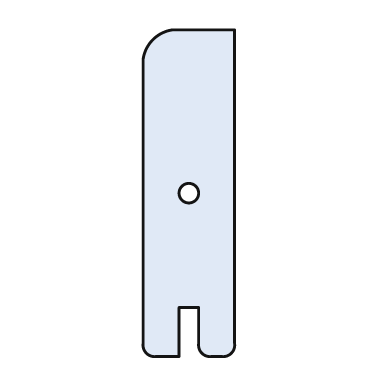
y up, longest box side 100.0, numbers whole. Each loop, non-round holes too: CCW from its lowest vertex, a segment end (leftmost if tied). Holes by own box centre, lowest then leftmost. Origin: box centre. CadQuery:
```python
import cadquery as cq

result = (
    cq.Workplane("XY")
    .moveTo(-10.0, -50.0)
    .lineTo(-3.0, -50.0)
    .lineTo(-3.0, -35.0)
    .lineTo(3.0, -35.0)
    .lineTo(3.0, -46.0)
    .threePointArc((4.0, -49.0), (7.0, -50.0))
    .lineTo(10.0, -50.0)
    .threePointArc((13.0, -49.0), (14.0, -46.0))
    .lineTo(14.0, 50.0)
    .lineTo(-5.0, 50.0)
    .threePointArc((-11.0, 47.0), (-14.0, 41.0))
    .lineTo(-14.0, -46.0)
    .threePointArc((-13.0, -49.0), (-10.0, -50.0))
    .close()
    .moveTo(0.0, 0.0)
    .circle(3.0)
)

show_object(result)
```